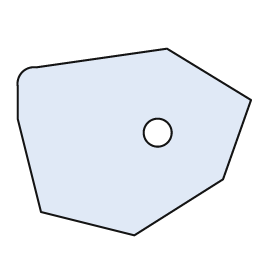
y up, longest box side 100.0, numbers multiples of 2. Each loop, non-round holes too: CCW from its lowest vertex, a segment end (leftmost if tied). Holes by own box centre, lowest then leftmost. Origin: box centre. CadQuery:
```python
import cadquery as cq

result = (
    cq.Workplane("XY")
    .moveTo(0.0, -40.0)
    .lineTo(38.0, -16.0)
    .lineTo(50.0, 18.0)
    .lineTo(14.0, 40.0)
    .lineTo(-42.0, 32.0)
    .threePointArc((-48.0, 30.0), (-50.0, 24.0))
    .lineTo(-50.0, 10.0)
    .lineTo(-40.0, -30.0)
    .close()
    .moveTo(10.0, 4.0)
    .circle(6.0)
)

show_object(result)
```